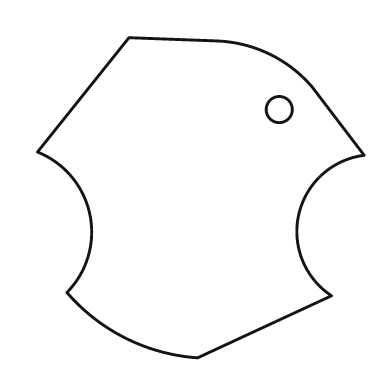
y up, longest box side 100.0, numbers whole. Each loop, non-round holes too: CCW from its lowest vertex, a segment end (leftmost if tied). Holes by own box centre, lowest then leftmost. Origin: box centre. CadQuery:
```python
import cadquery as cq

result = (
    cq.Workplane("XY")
    .moveTo(-1.0, -49.0)
    .lineTo(40.0, -30.0)
    .threePointArc((30.0, -5.0), (50.0, 13.0))
    .lineTo(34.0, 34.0)
    .threePointArc((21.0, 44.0), (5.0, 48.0))
    .lineTo(-22.0, 49.0)
    .lineTo(-50.0, 14.0)
    .threePointArc((-34.0, -5.0), (-41.0, -29.0))
    .threePointArc((-23.0, -43.0), (-1.0, -49.0))
    .close()
    .moveTo(24.0, 27.0)
    .circle(4.0)
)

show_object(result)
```